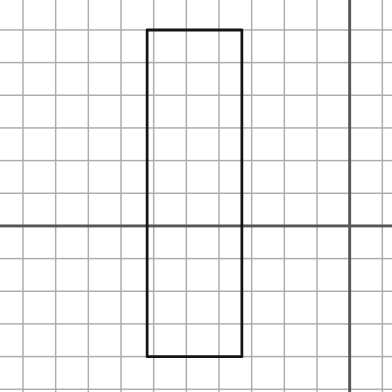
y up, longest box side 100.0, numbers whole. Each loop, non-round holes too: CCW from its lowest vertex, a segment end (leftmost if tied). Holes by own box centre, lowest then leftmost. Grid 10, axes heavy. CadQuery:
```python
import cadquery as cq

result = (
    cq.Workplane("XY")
    .moveTo(-62.0, -40.0)
    .lineTo(-33.0, -40.0)
    .lineTo(-33.0, 60.0)
    .lineTo(-62.0, 60.0)
    .close()
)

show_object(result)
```